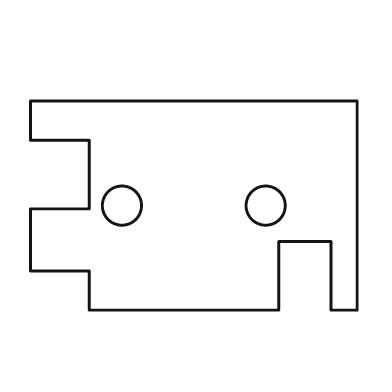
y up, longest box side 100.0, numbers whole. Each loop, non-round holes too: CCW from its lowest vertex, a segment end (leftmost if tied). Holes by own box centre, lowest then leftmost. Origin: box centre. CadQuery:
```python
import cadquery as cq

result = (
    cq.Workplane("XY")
    .moveTo(-32.0, -32.0)
    .lineTo(26.0, -32.0)
    .lineTo(26.0, -11.0)
    .lineTo(42.0, -11.0)
    .lineTo(42.0, -32.0)
    .lineTo(50.0, -32.0)
    .lineTo(50.0, 32.0)
    .lineTo(-50.0, 32.0)
    .lineTo(-50.0, 20.0)
    .lineTo(-32.0, 20.0)
    .lineTo(-32.0, -1.0)
    .lineTo(-50.0, -1.0)
    .lineTo(-50.0, -20.0)
    .lineTo(-32.0, -20.0)
    .close()
    .moveTo(-22.0, 0.0)
    .circle(6.0)
    .moveTo(22.0, 0.0)
    .circle(6.0)
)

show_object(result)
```